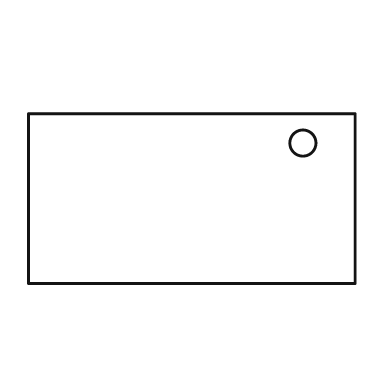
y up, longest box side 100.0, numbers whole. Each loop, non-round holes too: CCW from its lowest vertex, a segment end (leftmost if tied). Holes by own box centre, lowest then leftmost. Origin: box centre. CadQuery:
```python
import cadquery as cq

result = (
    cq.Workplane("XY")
    .moveTo(-50.0, -26.0)
    .lineTo(50.0, -26.0)
    .lineTo(50.0, 26.0)
    .lineTo(-50.0, 26.0)
    .close()
    .moveTo(34.0, 17.0)
    .circle(4.0)
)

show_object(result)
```